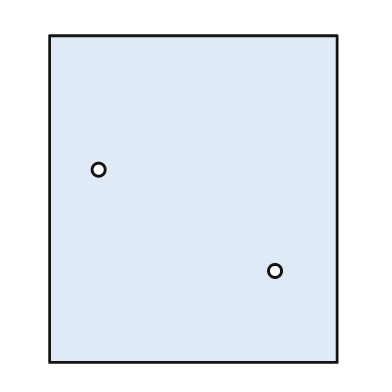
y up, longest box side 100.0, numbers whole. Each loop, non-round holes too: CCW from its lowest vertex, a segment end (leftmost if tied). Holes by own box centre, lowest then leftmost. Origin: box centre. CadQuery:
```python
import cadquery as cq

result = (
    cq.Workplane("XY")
    .moveTo(-44.0, -50.0)
    .lineTo(44.0, -50.0)
    .lineTo(44.0, 50.0)
    .lineTo(-44.0, 50.0)
    .close()
    .moveTo(25.0, -22.0)
    .circle(2.0)
    .moveTo(-29.0, 9.0)
    .circle(2.0)
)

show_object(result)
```